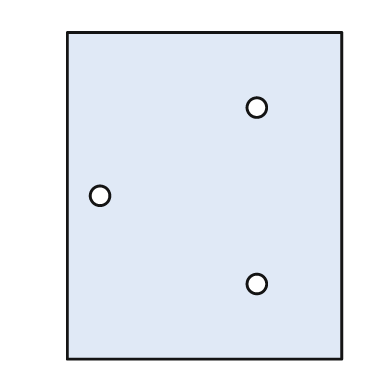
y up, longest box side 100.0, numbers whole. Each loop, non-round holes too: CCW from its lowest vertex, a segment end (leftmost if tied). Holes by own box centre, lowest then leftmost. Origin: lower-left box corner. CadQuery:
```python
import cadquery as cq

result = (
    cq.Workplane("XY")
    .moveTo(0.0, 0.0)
    .lineTo(84.0, 0.0)
    .lineTo(84.0, 100.0)
    .lineTo(0.0, 100.0)
    .close()
    .moveTo(58.0, 23.0)
    .circle(3.0)
    .moveTo(10.0, 50.0)
    .circle(3.0)
    .moveTo(58.0, 77.0)
    .circle(3.0)
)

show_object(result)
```